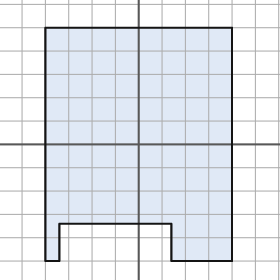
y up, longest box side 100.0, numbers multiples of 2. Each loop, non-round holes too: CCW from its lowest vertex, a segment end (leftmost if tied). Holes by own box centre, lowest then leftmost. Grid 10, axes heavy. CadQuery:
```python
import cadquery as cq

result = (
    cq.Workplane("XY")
    .moveTo(-40.0, -50.0)
    .lineTo(-34.0, -50.0)
    .lineTo(-34.0, -34.0)
    .lineTo(14.0, -34.0)
    .lineTo(14.0, -50.0)
    .lineTo(40.0, -50.0)
    .lineTo(40.0, 50.0)
    .lineTo(-40.0, 50.0)
    .close()
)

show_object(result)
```